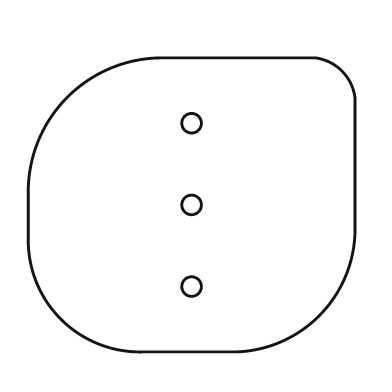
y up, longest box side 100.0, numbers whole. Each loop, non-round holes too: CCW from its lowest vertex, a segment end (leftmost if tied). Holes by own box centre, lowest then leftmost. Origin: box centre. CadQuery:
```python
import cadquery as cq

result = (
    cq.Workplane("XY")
    .moveTo(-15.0, -45.0)
    .lineTo(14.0, -45.0)
    .threePointArc((39.0, -34.0), (50.0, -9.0))
    .lineTo(50.0, 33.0)
    .threePointArc((46.0, 41.0), (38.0, 45.0))
    .lineTo(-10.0, 45.0)
    .threePointArc((-38.0, 33.0), (-50.0, 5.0))
    .lineTo(-50.0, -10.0)
    .threePointArc((-40.0, -35.0), (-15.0, -45.0))
    .close()
    .moveTo(0.0, -25.0)
    .circle(3.0)
    .moveTo(0.0, 0.0)
    .circle(3.0)
    .moveTo(0.0, 25.0)
    .circle(3.0)
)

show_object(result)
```